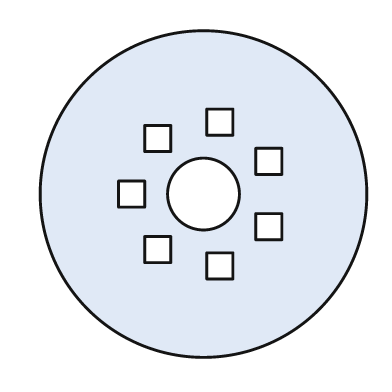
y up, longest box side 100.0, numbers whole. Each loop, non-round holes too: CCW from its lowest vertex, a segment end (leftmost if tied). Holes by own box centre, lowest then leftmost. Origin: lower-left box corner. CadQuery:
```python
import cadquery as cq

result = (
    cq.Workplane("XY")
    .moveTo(50.0, 50.0)
    .circle(50.0)
    .moveTo(51.0, 24.0)
    .lineTo(59.0, 24.0)
    .lineTo(59.0, 32.0)
    .lineTo(51.0, 32.0)
    .close()
    .moveTo(32.0, 29.0)
    .lineTo(40.0, 29.0)
    .lineTo(40.0, 37.0)
    .lineTo(32.0, 37.0)
    .close()
    .moveTo(66.0, 36.0)
    .lineTo(74.0, 36.0)
    .lineTo(74.0, 44.0)
    .lineTo(66.0, 44.0)
    .close()
    .moveTo(24.0, 46.0)
    .lineTo(32.0, 46.0)
    .lineTo(32.0, 54.0)
    .lineTo(24.0, 54.0)
    .close()
    .moveTo(50.0, 50.0)
    .circle(11.0)
    .moveTo(66.0, 56.0)
    .lineTo(74.0, 56.0)
    .lineTo(74.0, 64.0)
    .lineTo(66.0, 64.0)
    .close()
    .moveTo(32.0, 63.0)
    .lineTo(40.0, 63.0)
    .lineTo(40.0, 71.0)
    .lineTo(32.0, 71.0)
    .close()
    .moveTo(51.0, 68.0)
    .lineTo(59.0, 68.0)
    .lineTo(59.0, 76.0)
    .lineTo(51.0, 76.0)
    .close()
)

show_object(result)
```